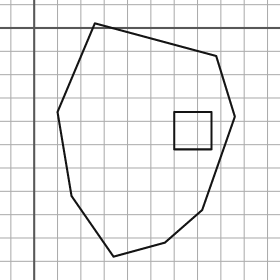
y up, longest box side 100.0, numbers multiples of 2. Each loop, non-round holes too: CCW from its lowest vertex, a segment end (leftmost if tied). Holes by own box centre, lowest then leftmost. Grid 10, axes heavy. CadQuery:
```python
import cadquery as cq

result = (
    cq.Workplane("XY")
    .moveTo(34.0, -98.0)
    .lineTo(56.0, -92.0)
    .lineTo(72.0, -78.0)
    .lineTo(86.0, -38.0)
    .lineTo(78.0, -12.0)
    .lineTo(26.0, 2.0)
    .lineTo(10.0, -36.0)
    .lineTo(16.0, -72.0)
    .close()
    .moveTo(60.0, -52.0)
    .lineTo(76.0, -52.0)
    .lineTo(76.0, -36.0)
    .lineTo(60.0, -36.0)
    .close()
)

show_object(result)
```